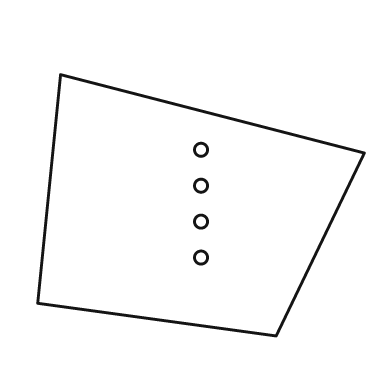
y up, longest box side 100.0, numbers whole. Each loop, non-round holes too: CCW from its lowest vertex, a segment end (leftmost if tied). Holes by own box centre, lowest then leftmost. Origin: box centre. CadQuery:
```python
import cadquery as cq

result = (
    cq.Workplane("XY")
    .moveTo(23.0, -40.0)
    .lineTo(50.0, 16.0)
    .lineTo(-43.0, 40.0)
    .lineTo(-50.0, -30.0)
    .close()
    .moveTo(0.0, -16.0)
    .circle(2.0)
    .moveTo(0.0, -5.0)
    .circle(2.0)
    .moveTo(0.0, 6.0)
    .circle(2.0)
    .moveTo(0.0, 17.0)
    .circle(2.0)
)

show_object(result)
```